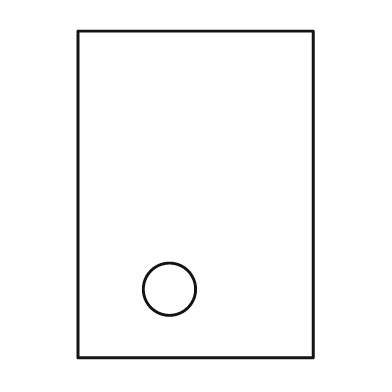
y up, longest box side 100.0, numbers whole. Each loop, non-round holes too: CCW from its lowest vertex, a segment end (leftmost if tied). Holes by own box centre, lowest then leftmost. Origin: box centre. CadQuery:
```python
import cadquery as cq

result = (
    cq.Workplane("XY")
    .moveTo(-36.0, -50.0)
    .lineTo(36.0, -50.0)
    .lineTo(36.0, 50.0)
    .lineTo(-36.0, 50.0)
    .close()
    .moveTo(-8.0, -29.0)
    .circle(8.0)
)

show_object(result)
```